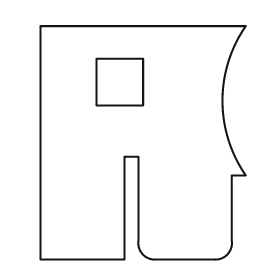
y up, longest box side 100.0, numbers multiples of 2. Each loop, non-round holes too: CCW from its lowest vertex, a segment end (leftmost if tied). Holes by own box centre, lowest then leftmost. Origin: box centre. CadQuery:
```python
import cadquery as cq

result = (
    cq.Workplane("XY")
    .moveTo(-44.0, -50.0)
    .lineTo(-8.0, -50.0)
    .lineTo(-8.0, -6.0)
    .lineTo(-2.0, -6.0)
    .lineTo(-2.0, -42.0)
    .threePointArc((0.0, -48.0), (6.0, -50.0))
    .lineTo(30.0, -50.0)
    .threePointArc((36.0, -48.0), (38.0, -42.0))
    .lineTo(38.0, -14.0)
    .lineTo(44.0, -14.0)
    .threePointArc((34.0, 18.0), (44.0, 50.0))
    .lineTo(-44.0, 50.0)
    .close()
    .moveTo(-20.0, 16.0)
    .lineTo(0.0, 16.0)
    .lineTo(0.0, 36.0)
    .lineTo(-20.0, 36.0)
    .close()
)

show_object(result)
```